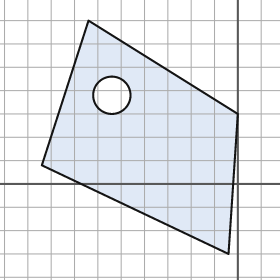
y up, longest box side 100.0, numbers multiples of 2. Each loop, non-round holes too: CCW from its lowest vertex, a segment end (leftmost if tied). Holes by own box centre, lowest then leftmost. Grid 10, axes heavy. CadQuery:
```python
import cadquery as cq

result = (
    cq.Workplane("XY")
    .moveTo(-4.0, -30.0)
    .lineTo(0.0, 30.0)
    .lineTo(-64.0, 70.0)
    .lineTo(-84.0, 8.0)
    .close()
    .moveTo(-54.0, 38.0)
    .circle(8.0)
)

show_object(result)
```